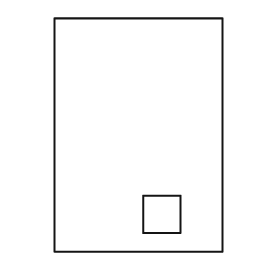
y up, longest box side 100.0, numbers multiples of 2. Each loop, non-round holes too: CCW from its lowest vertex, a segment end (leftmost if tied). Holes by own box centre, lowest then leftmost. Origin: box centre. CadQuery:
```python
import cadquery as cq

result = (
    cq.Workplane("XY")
    .moveTo(-36.0, -50.0)
    .lineTo(36.0, -50.0)
    .lineTo(36.0, 50.0)
    .lineTo(-36.0, 50.0)
    .close()
    .moveTo(2.0, -42.0)
    .lineTo(18.0, -42.0)
    .lineTo(18.0, -26.0)
    .lineTo(2.0, -26.0)
    .close()
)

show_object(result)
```